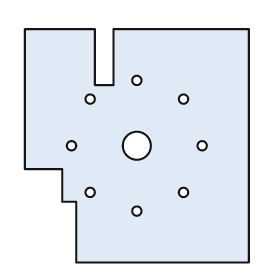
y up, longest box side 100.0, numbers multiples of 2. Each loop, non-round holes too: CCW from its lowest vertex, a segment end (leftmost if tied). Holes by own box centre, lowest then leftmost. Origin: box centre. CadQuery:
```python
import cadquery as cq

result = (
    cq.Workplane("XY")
    .moveTo(-26.0, -50.0)
    .lineTo(48.0, -50.0)
    .lineTo(48.0, 50.0)
    .lineTo(-10.0, 50.0)
    .lineTo(-10.0, 26.0)
    .lineTo(-18.0, 26.0)
    .lineTo(-18.0, 50.0)
    .lineTo(-48.0, 50.0)
    .lineTo(-48.0, -10.0)
    .lineTo(-32.0, -10.0)
    .lineTo(-32.0, -24.0)
    .lineTo(-26.0, -24.0)
    .close()
    .moveTo(0.0, -28.0)
    .circle(2.0)
    .moveTo(-20.0, -20.0)
    .circle(2.0)
    .moveTo(20.0, -20.0)
    .circle(2.0)
    .moveTo(-28.0, 0.0)
    .circle(2.0)
    .moveTo(0.0, 0.0)
    .circle(6.0)
    .moveTo(28.0, 0.0)
    .circle(2.0)
    .moveTo(-20.0, 20.0)
    .circle(2.0)
    .moveTo(20.0, 20.0)
    .circle(2.0)
    .moveTo(0.0, 28.0)
    .circle(2.0)
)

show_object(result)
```